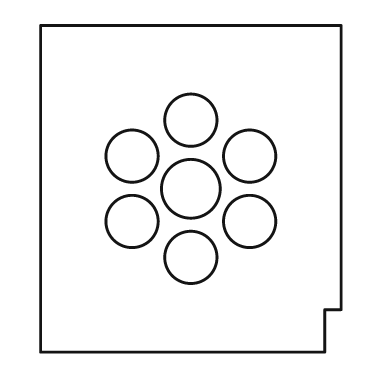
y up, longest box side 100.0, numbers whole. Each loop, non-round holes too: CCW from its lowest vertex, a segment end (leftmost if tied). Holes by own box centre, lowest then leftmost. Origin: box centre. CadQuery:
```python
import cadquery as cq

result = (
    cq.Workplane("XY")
    .moveTo(-46.0, -50.0)
    .lineTo(41.0, -50.0)
    .lineTo(41.0, -37.0)
    .lineTo(46.0, -37.0)
    .lineTo(46.0, 50.0)
    .lineTo(-46.0, 50.0)
    .close()
    .moveTo(0.0, -21.0)
    .circle(8.0)
    .moveTo(-18.0, -10.0)
    .circle(8.0)
    .moveTo(18.0, -10.0)
    .circle(8.0)
    .moveTo(0.0, 0.0)
    .circle(9.0)
    .moveTo(-18.0, 10.0)
    .circle(8.0)
    .moveTo(18.0, 10.0)
    .circle(8.0)
    .moveTo(0.0, 21.0)
    .circle(8.0)
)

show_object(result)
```